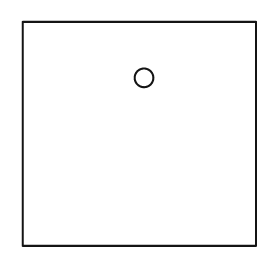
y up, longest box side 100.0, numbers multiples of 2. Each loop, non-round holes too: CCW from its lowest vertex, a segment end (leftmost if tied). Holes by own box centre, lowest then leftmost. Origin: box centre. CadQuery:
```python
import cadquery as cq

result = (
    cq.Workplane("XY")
    .moveTo(-50.0, -48.0)
    .lineTo(50.0, -48.0)
    .lineTo(50.0, 48.0)
    .lineTo(-50.0, 48.0)
    .close()
    .moveTo(2.0, 24.0)
    .circle(4.0)
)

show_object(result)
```